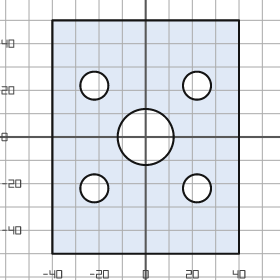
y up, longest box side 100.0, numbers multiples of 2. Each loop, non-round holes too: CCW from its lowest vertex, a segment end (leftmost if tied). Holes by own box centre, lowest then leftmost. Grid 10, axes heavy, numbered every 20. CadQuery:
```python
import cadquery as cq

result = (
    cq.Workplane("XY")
    .moveTo(-40.0, -50.0)
    .lineTo(40.0, -50.0)
    .lineTo(40.0, 50.0)
    .lineTo(-40.0, 50.0)
    .close()
    .moveTo(-22.0, -22.0)
    .circle(6.0)
    .moveTo(22.0, -22.0)
    .circle(6.0)
    .moveTo(0.0, 0.0)
    .circle(12.0)
    .moveTo(-22.0, 22.0)
    .circle(6.0)
    .moveTo(22.0, 22.0)
    .circle(6.0)
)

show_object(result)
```